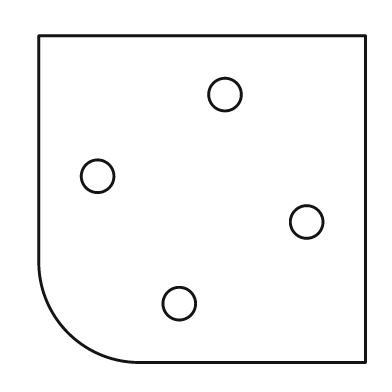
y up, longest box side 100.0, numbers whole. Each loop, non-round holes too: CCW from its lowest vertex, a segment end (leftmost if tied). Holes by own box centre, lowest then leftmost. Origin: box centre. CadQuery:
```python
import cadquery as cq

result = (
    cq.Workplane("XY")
    .moveTo(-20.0, -50.0)
    .lineTo(50.0, -50.0)
    .lineTo(50.0, 50.0)
    .lineTo(-50.0, 50.0)
    .lineTo(-50.0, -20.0)
    .threePointArc((-41.0, -41.0), (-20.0, -50.0))
    .close()
    .moveTo(-7.0, -32.0)
    .circle(5.0)
    .moveTo(32.0, -7.0)
    .circle(5.0)
    .moveTo(-32.0, 7.0)
    .circle(5.0)
    .moveTo(7.0, 32.0)
    .circle(5.0)
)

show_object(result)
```